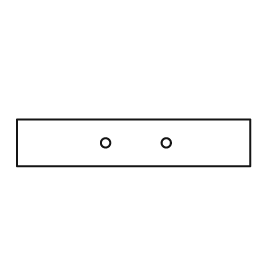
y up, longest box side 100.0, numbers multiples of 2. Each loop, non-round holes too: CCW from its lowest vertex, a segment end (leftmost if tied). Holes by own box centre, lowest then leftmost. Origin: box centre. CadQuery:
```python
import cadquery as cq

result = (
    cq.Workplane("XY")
    .moveTo(-50.0, -10.0)
    .lineTo(50.0, -10.0)
    .lineTo(50.0, 10.0)
    .lineTo(-50.0, 10.0)
    .close()
    .moveTo(-12.0, 0.0)
    .circle(2.0)
    .moveTo(14.0, 0.0)
    .circle(2.0)
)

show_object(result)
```